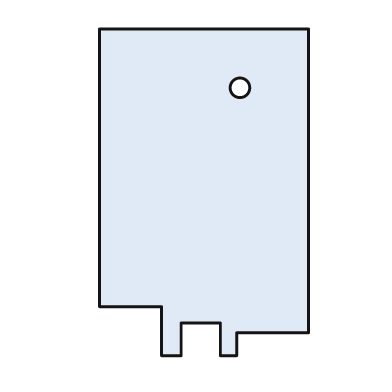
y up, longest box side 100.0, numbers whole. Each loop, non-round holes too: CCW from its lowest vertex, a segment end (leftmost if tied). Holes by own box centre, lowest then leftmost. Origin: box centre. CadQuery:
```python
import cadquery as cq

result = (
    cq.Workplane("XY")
    .moveTo(-13.0, -50.0)
    .lineTo(-7.0, -50.0)
    .lineTo(-7.0, -40.0)
    .lineTo(5.0, -40.0)
    .lineTo(5.0, -50.0)
    .lineTo(10.0, -50.0)
    .lineTo(10.0, -43.0)
    .lineTo(32.0, -43.0)
    .lineTo(32.0, 50.0)
    .lineTo(-32.0, 50.0)
    .lineTo(-32.0, -35.0)
    .lineTo(-13.0, -35.0)
    .close()
    .moveTo(11.0, 32.0)
    .circle(3.0)
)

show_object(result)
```